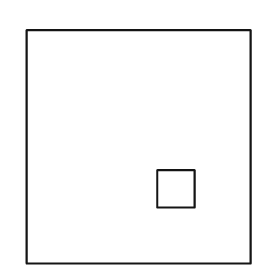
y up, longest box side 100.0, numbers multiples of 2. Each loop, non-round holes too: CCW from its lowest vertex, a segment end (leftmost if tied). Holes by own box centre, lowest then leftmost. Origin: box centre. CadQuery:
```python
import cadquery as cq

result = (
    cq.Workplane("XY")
    .moveTo(-48.0, -50.0)
    .lineTo(48.0, -50.0)
    .lineTo(48.0, 50.0)
    .lineTo(-48.0, 50.0)
    .close()
    .moveTo(8.0, -26.0)
    .lineTo(24.0, -26.0)
    .lineTo(24.0, -10.0)
    .lineTo(8.0, -10.0)
    .close()
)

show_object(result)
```